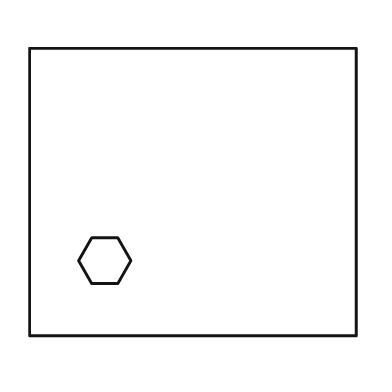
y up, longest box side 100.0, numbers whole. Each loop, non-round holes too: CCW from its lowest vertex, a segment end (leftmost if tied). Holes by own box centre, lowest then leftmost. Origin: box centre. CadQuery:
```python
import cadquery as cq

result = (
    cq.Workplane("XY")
    .moveTo(-50.0, -44.0)
    .lineTo(50.0, -44.0)
    .lineTo(50.0, 44.0)
    .lineTo(-50.0, 44.0)
    .close()
    .moveTo(-31.0, -28.0)
    .lineTo(-23.0, -28.0)
    .lineTo(-19.0, -21.0)
    .lineTo(-23.0, -14.0)
    .lineTo(-31.0, -14.0)
    .lineTo(-35.0, -21.0)
    .close()
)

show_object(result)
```